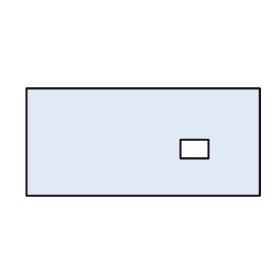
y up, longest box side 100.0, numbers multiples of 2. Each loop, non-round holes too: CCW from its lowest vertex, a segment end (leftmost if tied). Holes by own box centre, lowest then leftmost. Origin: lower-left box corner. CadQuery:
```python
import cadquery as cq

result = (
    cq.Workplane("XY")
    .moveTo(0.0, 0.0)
    .lineTo(100.0, 0.0)
    .lineTo(100.0, 46.0)
    .lineTo(0.0, 46.0)
    .close()
    .moveTo(66.0, 16.0)
    .lineTo(78.0, 16.0)
    .lineTo(78.0, 24.0)
    .lineTo(66.0, 24.0)
    .close()
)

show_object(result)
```